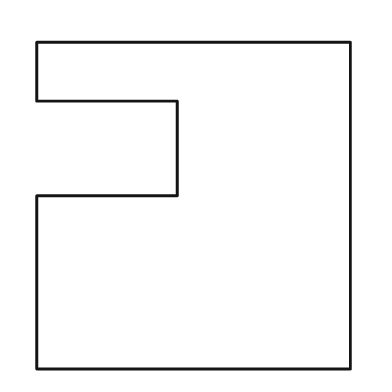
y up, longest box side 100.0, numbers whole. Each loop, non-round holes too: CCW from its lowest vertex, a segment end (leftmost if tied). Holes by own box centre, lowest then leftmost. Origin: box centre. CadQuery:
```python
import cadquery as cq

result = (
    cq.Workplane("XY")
    .moveTo(-48.0, -50.0)
    .lineTo(48.0, -50.0)
    .lineTo(48.0, 50.0)
    .lineTo(-48.0, 50.0)
    .lineTo(-48.0, 32.0)
    .lineTo(-5.0, 32.0)
    .lineTo(-5.0, 3.0)
    .lineTo(-48.0, 3.0)
    .close()
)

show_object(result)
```